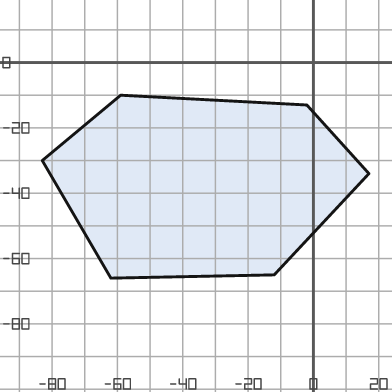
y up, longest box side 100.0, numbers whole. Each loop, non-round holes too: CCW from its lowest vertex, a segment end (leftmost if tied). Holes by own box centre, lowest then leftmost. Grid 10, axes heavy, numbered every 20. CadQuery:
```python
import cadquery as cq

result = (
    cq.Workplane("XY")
    .moveTo(-62.0, -66.0)
    .lineTo(-12.0, -65.0)
    .lineTo(17.0, -34.0)
    .lineTo(-2.0, -13.0)
    .lineTo(-59.0, -10.0)
    .lineTo(-83.0, -30.0)
    .close()
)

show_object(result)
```